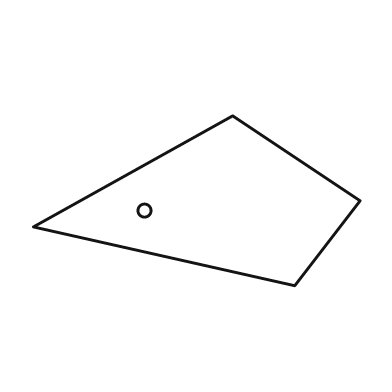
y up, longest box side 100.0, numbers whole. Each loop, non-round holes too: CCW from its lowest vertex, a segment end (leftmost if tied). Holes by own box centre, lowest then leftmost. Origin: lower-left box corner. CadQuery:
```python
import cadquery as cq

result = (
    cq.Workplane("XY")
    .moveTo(80.0, 0.0)
    .lineTo(100.0, 26.0)
    .lineTo(61.0, 52.0)
    .lineTo(0.0, 18.0)
    .close()
    .moveTo(34.0, 23.0)
    .circle(2.0)
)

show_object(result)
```